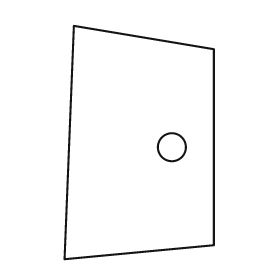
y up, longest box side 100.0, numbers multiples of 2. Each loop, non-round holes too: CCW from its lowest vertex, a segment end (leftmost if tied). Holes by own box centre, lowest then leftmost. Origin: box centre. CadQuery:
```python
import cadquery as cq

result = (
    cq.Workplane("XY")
    .moveTo(-32.0, -50.0)
    .lineTo(32.0, -44.0)
    .lineTo(32.0, 40.0)
    .lineTo(-28.0, 50.0)
    .close()
    .moveTo(14.0, -2.0)
    .circle(6.0)
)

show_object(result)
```